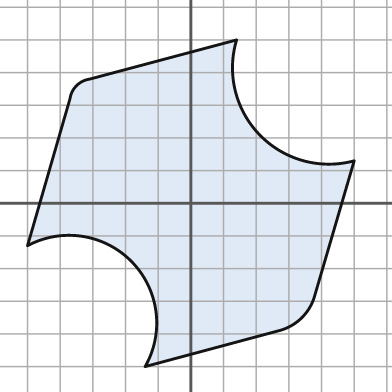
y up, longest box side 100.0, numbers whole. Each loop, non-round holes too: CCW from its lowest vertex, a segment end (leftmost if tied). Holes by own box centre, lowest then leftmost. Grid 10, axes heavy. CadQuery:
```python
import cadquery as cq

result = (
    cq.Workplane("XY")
    .moveTo(-14.0, -50.0)
    .lineTo(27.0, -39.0)
    .threePointArc((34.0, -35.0), (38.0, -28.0))
    .lineTo(50.0, 13.0)
    .threePointArc((21.0, 21.0), (14.0, 50.0))
    .lineTo(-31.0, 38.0)
    .threePointArc((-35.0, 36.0), (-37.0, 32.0))
    .lineTo(-50.0, -13.0)
    .threePointArc((-18.0, -18.0), (-14.0, -50.0))
    .close()
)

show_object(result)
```